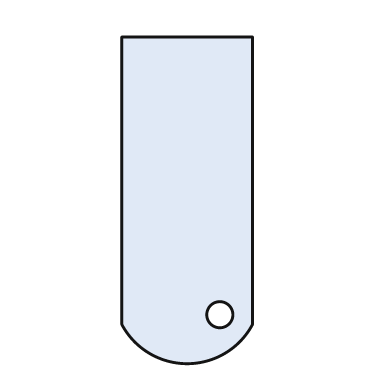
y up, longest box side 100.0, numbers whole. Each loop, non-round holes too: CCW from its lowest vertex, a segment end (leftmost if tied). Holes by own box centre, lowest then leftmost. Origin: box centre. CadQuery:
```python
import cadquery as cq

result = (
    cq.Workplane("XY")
    .moveTo(-20.0, -38.0)
    .threePointArc((0.0, -50.0), (20.0, -38.0))
    .lineTo(20.0, 50.0)
    .lineTo(-20.0, 50.0)
    .close()
    .moveTo(10.0, -35.0)
    .circle(4.0)
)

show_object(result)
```